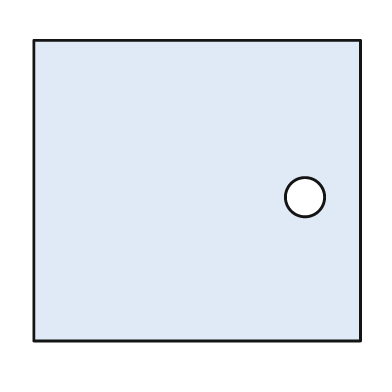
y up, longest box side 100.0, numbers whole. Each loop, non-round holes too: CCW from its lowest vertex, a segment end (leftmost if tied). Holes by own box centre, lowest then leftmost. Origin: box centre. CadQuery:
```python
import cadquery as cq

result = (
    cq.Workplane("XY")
    .moveTo(-50.0, -46.0)
    .lineTo(50.0, -46.0)
    .lineTo(50.0, 46.0)
    .lineTo(-50.0, 46.0)
    .close()
    .moveTo(33.0, -2.0)
    .circle(6.0)
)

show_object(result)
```